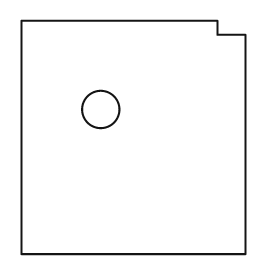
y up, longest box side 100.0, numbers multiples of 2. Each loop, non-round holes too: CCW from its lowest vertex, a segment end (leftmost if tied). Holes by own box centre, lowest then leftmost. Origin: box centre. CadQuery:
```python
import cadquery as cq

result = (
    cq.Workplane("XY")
    .moveTo(-48.0, -50.0)
    .lineTo(48.0, -50.0)
    .lineTo(48.0, 44.0)
    .lineTo(36.0, 44.0)
    .lineTo(36.0, 50.0)
    .lineTo(-48.0, 50.0)
    .close()
    .moveTo(-14.0, 12.0)
    .circle(8.0)
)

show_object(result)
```